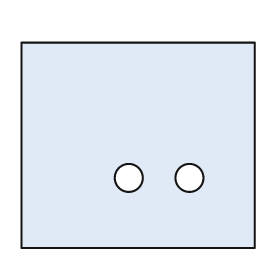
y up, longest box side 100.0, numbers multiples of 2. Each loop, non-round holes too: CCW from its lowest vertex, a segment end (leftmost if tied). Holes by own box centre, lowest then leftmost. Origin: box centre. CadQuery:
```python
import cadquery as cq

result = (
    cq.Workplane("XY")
    .moveTo(-50.0, -44.0)
    .lineTo(50.0, -44.0)
    .lineTo(50.0, 44.0)
    .lineTo(-50.0, 44.0)
    .close()
    .moveTo(-4.0, -14.0)
    .circle(6.0)
    .moveTo(22.0, -14.0)
    .circle(6.0)
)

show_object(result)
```